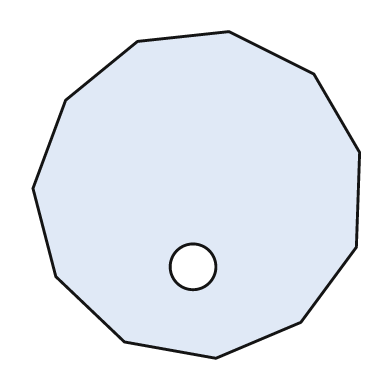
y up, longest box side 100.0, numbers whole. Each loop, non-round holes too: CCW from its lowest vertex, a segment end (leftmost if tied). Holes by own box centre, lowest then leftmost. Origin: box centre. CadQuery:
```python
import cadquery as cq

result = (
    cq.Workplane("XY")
    .moveTo(6.0, -50.0)
    .lineTo(32.0, -39.0)
    .lineTo(49.0, -16.0)
    .lineTo(50.0, 13.0)
    .lineTo(36.0, 37.0)
    .lineTo(10.0, 50.0)
    .lineTo(-18.0, 47.0)
    .lineTo(-40.0, 29.0)
    .lineTo(-50.0, 2.0)
    .lineTo(-43.0, -25.0)
    .lineTo(-22.0, -45.0)
    .close()
    .moveTo(-1.0, -22.0)
    .circle(7.0)
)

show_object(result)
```